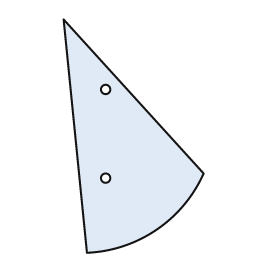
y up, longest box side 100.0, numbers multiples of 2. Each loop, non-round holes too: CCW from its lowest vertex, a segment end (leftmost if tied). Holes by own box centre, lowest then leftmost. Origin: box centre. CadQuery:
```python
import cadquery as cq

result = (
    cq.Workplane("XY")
    .moveTo(-20.0, -50.0)
    .threePointArc((10.0, -40.0), (30.0, -16.0))
    .lineTo(-30.0, 50.0)
    .close()
    .moveTo(-12.0, -18.0)
    .circle(2.0)
    .moveTo(-12.0, 20.0)
    .circle(2.0)
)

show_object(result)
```